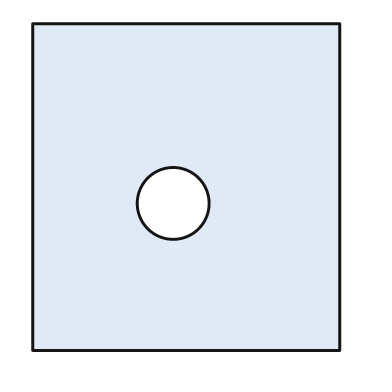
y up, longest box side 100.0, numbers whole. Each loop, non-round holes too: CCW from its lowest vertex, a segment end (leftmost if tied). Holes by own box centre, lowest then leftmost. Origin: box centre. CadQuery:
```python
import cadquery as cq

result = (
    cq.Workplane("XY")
    .moveTo(-47.0, -50.0)
    .lineTo(47.0, -50.0)
    .lineTo(47.0, 50.0)
    .lineTo(-47.0, 50.0)
    .close()
    .moveTo(-4.0, -5.0)
    .circle(11.0)
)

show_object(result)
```